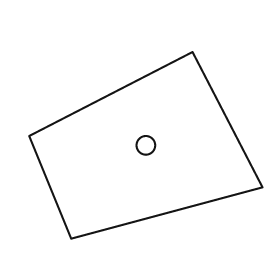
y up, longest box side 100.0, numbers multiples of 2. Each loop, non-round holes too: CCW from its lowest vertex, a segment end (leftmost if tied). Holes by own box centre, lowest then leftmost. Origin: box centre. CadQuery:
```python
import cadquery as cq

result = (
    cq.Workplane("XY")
    .moveTo(-32.0, -40.0)
    .lineTo(50.0, -18.0)
    .lineTo(20.0, 40.0)
    .lineTo(-50.0, 4.0)
    .close()
    .moveTo(0.0, 0.0)
    .circle(4.0)
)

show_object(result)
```